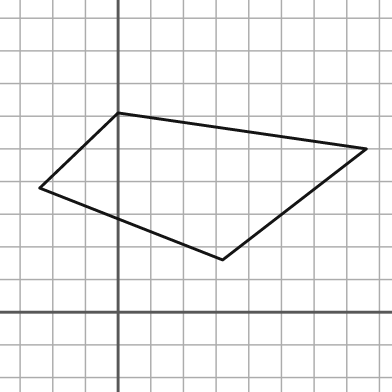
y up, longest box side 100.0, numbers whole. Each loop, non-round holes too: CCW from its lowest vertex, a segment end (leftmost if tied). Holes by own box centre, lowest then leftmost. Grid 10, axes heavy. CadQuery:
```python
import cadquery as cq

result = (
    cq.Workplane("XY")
    .moveTo(32.0, 16.0)
    .lineTo(76.0, 50.0)
    .lineTo(0.0, 61.0)
    .lineTo(-24.0, 38.0)
    .close()
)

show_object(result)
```